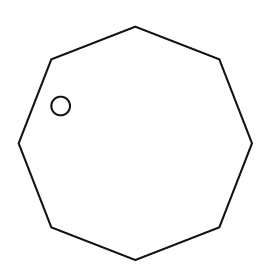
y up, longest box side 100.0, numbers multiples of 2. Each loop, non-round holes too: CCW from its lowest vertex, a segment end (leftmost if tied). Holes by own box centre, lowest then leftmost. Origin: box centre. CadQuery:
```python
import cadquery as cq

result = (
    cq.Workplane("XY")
    .moveTo(0.0, -50.0)
    .lineTo(36.0, -36.0)
    .lineTo(50.0, 0.0)
    .lineTo(36.0, 36.0)
    .lineTo(0.0, 50.0)
    .lineTo(-36.0, 36.0)
    .lineTo(-50.0, 0.0)
    .lineTo(-36.0, -36.0)
    .close()
    .moveTo(-32.0, 16.0)
    .circle(4.0)
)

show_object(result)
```